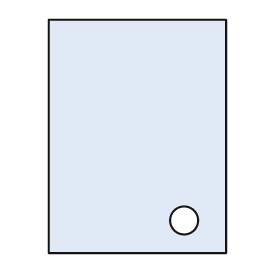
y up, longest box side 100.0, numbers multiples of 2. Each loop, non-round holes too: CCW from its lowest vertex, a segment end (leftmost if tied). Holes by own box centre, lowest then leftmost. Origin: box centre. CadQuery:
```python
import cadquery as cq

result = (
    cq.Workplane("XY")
    .moveTo(-38.0, -50.0)
    .lineTo(38.0, -50.0)
    .lineTo(38.0, 50.0)
    .lineTo(-38.0, 50.0)
    .close()
    .moveTo(20.0, -36.0)
    .circle(6.0)
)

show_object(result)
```